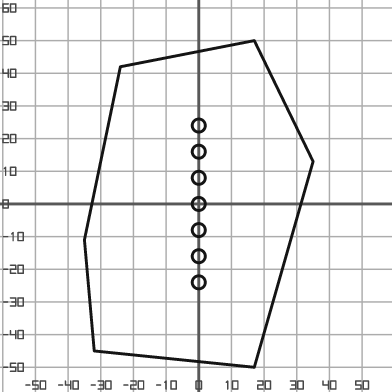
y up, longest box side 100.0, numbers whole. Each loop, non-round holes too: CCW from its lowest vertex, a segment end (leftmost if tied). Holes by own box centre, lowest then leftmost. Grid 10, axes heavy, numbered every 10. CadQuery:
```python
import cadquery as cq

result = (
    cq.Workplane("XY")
    .moveTo(17.0, -50.0)
    .lineTo(35.0, 13.0)
    .lineTo(17.0, 50.0)
    .lineTo(-24.0, 42.0)
    .lineTo(-35.0, -11.0)
    .lineTo(-32.0, -45.0)
    .close()
    .moveTo(0.0, -24.0)
    .circle(2.0)
    .moveTo(0.0, -16.0)
    .circle(2.0)
    .moveTo(0.0, -8.0)
    .circle(2.0)
    .moveTo(0.0, 0.0)
    .circle(2.0)
    .moveTo(0.0, 8.0)
    .circle(2.0)
    .moveTo(0.0, 16.0)
    .circle(2.0)
    .moveTo(0.0, 24.0)
    .circle(2.0)
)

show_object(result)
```